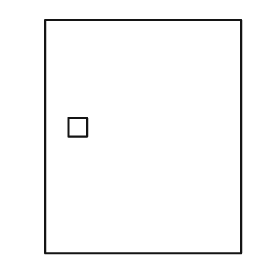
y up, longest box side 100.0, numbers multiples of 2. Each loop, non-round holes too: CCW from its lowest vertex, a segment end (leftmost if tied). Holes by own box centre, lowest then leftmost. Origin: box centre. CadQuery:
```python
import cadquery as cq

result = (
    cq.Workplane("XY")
    .moveTo(-42.0, -50.0)
    .lineTo(42.0, -50.0)
    .lineTo(42.0, 50.0)
    .lineTo(-42.0, 50.0)
    .close()
    .moveTo(-32.0, 0.0)
    .lineTo(-24.0, 0.0)
    .lineTo(-24.0, 8.0)
    .lineTo(-32.0, 8.0)
    .close()
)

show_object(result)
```